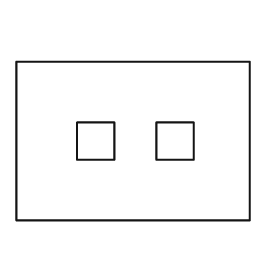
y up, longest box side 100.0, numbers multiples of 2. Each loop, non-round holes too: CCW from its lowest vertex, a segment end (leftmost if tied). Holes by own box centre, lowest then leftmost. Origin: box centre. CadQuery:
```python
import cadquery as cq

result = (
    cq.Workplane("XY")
    .moveTo(-50.0, -34.0)
    .lineTo(50.0, -34.0)
    .lineTo(50.0, 34.0)
    .lineTo(-50.0, 34.0)
    .close()
    .moveTo(-24.0, -8.0)
    .lineTo(-8.0, -8.0)
    .lineTo(-8.0, 8.0)
    .lineTo(-24.0, 8.0)
    .close()
    .moveTo(10.0, -8.0)
    .lineTo(26.0, -8.0)
    .lineTo(26.0, 8.0)
    .lineTo(10.0, 8.0)
    .close()
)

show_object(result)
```